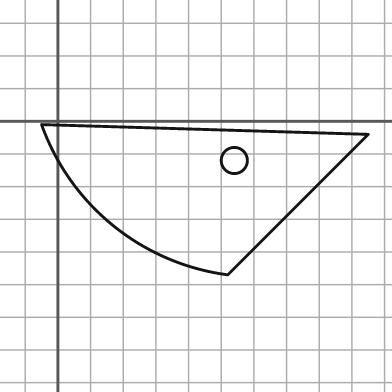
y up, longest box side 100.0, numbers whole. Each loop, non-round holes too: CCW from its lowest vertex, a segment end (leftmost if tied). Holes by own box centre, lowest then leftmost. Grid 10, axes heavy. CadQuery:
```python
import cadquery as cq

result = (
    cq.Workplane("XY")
    .moveTo(52.0, -47.0)
    .lineTo(95.0, -4.0)
    .lineTo(-5.0, -1.0)
    .threePointArc((17.0, -32.0), (52.0, -47.0))
    .close()
    .moveTo(54.0, -12.0)
    .circle(4.0)
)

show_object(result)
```